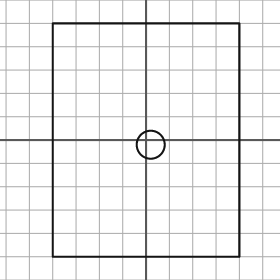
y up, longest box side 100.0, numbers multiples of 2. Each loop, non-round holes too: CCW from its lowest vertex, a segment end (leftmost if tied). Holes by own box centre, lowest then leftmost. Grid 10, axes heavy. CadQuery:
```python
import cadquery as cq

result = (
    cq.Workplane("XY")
    .moveTo(-40.0, -50.0)
    .lineTo(40.0, -50.0)
    .lineTo(40.0, 50.0)
    .lineTo(-40.0, 50.0)
    .close()
    .moveTo(2.0, -2.0)
    .circle(6.0)
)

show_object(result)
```